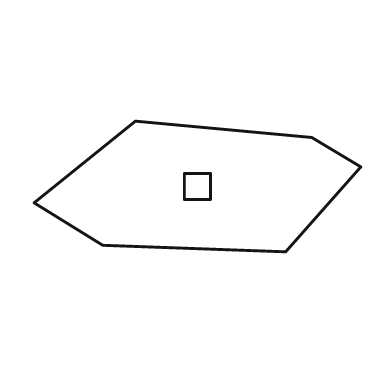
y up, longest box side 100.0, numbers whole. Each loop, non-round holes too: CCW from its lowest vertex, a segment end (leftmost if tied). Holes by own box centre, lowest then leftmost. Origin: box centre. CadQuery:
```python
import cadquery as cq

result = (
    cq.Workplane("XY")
    .moveTo(27.0, -20.0)
    .lineTo(50.0, 6.0)
    .lineTo(35.0, 15.0)
    .lineTo(-19.0, 20.0)
    .lineTo(-50.0, -5.0)
    .lineTo(-29.0, -18.0)
    .close()
    .moveTo(-4.0, -4.0)
    .lineTo(4.0, -4.0)
    .lineTo(4.0, 4.0)
    .lineTo(-4.0, 4.0)
    .close()
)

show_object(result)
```